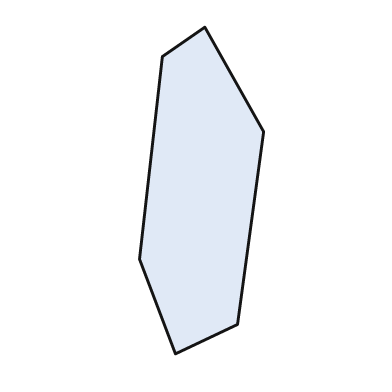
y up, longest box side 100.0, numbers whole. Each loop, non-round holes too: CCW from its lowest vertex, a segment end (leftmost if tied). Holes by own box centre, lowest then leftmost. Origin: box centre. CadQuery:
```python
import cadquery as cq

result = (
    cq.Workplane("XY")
    .moveTo(-8.0, -50.0)
    .lineTo(11.0, -41.0)
    .lineTo(19.0, 18.0)
    .lineTo(1.0, 50.0)
    .lineTo(-12.0, 41.0)
    .lineTo(-19.0, -21.0)
    .close()
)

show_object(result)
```